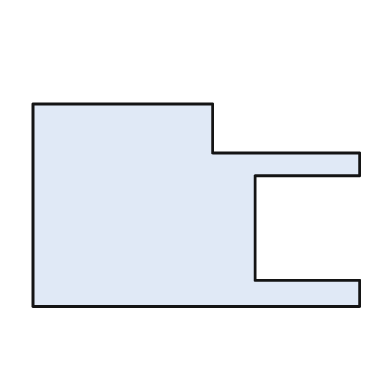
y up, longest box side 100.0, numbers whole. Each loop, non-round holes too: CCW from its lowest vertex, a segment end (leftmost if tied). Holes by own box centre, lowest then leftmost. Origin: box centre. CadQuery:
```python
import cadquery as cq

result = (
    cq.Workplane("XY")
    .moveTo(-50.0, -31.0)
    .lineTo(50.0, -31.0)
    .lineTo(50.0, -23.0)
    .lineTo(18.0, -23.0)
    .lineTo(18.0, 9.0)
    .lineTo(50.0, 9.0)
    .lineTo(50.0, 16.0)
    .lineTo(5.0, 16.0)
    .lineTo(5.0, 31.0)
    .lineTo(-50.0, 31.0)
    .close()
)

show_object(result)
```